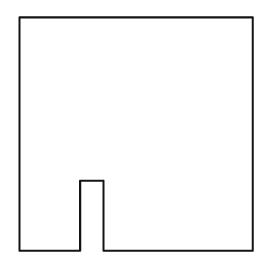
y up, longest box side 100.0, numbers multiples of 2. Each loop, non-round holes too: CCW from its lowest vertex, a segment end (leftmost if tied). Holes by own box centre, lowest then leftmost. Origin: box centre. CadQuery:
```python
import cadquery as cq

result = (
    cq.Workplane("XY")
    .moveTo(-50.0, -50.0)
    .lineTo(-24.0, -50.0)
    .lineTo(-24.0, -20.0)
    .lineTo(-14.0, -20.0)
    .lineTo(-14.0, -50.0)
    .lineTo(50.0, -50.0)
    .lineTo(50.0, 50.0)
    .lineTo(-50.0, 50.0)
    .close()
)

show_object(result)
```